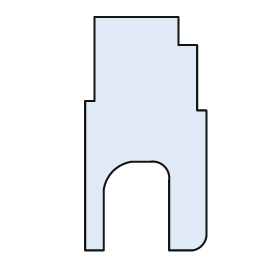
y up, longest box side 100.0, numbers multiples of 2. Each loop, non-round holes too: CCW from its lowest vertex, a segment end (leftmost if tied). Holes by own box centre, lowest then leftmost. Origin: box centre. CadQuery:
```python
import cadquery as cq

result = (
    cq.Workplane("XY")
    .moveTo(-26.0, -50.0)
    .lineTo(-18.0, -50.0)
    .lineTo(-18.0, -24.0)
    .threePointArc((-14.0, -16.0), (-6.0, -12.0))
    .lineTo(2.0, -12.0)
    .threePointArc((8.0, -14.0), (10.0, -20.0))
    .lineTo(10.0, -50.0)
    .lineTo(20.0, -50.0)
    .threePointArc((24.0, -48.0), (26.0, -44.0))
    .lineTo(26.0, 10.0)
    .lineTo(22.0, 10.0)
    .lineTo(22.0, 38.0)
    .lineTo(14.0, 38.0)
    .lineTo(14.0, 50.0)
    .lineTo(-22.0, 50.0)
    .lineTo(-22.0, 14.0)
    .lineTo(-26.0, 14.0)
    .close()
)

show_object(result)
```